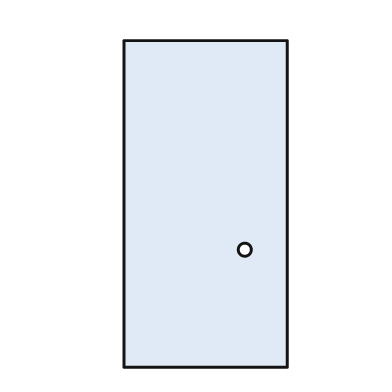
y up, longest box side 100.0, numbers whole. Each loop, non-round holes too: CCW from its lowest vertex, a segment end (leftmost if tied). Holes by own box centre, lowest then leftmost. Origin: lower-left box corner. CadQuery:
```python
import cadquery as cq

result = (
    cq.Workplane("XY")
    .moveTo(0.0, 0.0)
    .lineTo(50.0, 0.0)
    .lineTo(50.0, 100.0)
    .lineTo(0.0, 100.0)
    .close()
    .moveTo(37.0, 36.0)
    .circle(2.0)
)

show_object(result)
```